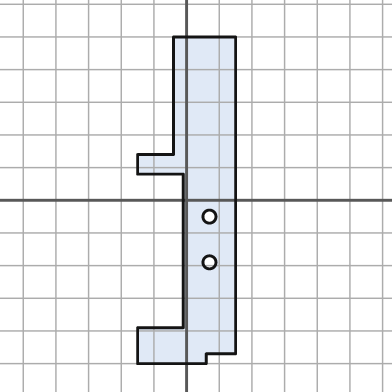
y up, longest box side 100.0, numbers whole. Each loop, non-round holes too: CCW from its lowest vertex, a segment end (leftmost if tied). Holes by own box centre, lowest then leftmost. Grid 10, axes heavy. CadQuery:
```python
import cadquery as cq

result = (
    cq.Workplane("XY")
    .moveTo(-15.0, -50.0)
    .lineTo(6.0, -50.0)
    .lineTo(6.0, -47.0)
    .lineTo(15.0, -47.0)
    .lineTo(15.0, 50.0)
    .lineTo(-4.0, 50.0)
    .lineTo(-4.0, 14.0)
    .lineTo(-15.0, 14.0)
    .lineTo(-15.0, 8.0)
    .lineTo(-1.0, 8.0)
    .lineTo(-1.0, -39.0)
    .lineTo(-15.0, -39.0)
    .close()
    .moveTo(7.0, -19.0)
    .circle(2.0)
    .moveTo(7.0, -5.0)
    .circle(2.0)
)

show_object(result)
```